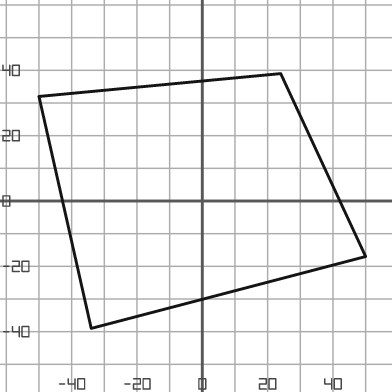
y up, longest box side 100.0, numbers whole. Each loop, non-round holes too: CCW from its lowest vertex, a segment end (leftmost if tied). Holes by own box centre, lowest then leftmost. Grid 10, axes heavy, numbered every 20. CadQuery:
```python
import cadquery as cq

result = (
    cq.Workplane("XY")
    .moveTo(-34.0, -39.0)
    .lineTo(50.0, -17.0)
    .lineTo(24.0, 39.0)
    .lineTo(-50.0, 32.0)
    .close()
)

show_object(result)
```